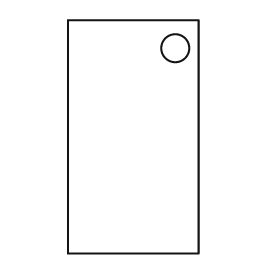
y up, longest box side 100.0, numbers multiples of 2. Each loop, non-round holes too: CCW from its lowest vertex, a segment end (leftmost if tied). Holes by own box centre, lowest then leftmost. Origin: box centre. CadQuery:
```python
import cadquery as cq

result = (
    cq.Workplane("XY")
    .moveTo(-28.0, -50.0)
    .lineTo(28.0, -50.0)
    .lineTo(28.0, 50.0)
    .lineTo(-28.0, 50.0)
    .close()
    .moveTo(18.0, 38.0)
    .circle(6.0)
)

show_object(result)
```